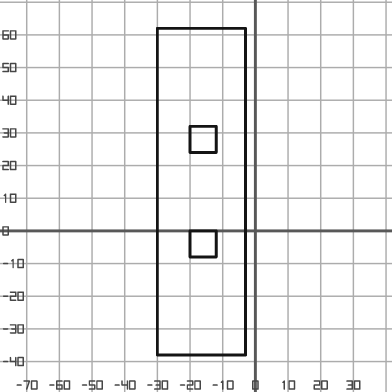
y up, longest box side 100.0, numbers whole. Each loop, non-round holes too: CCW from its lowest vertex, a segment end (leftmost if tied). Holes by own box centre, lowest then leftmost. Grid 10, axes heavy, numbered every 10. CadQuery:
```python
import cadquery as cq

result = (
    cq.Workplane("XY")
    .moveTo(-30.0, -38.0)
    .lineTo(-3.0, -38.0)
    .lineTo(-3.0, 62.0)
    .lineTo(-30.0, 62.0)
    .close()
    .moveTo(-20.0, -8.0)
    .lineTo(-12.0, -8.0)
    .lineTo(-12.0, 0.0)
    .lineTo(-20.0, 0.0)
    .close()
    .moveTo(-20.0, 24.0)
    .lineTo(-12.0, 24.0)
    .lineTo(-12.0, 32.0)
    .lineTo(-20.0, 32.0)
    .close()
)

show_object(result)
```